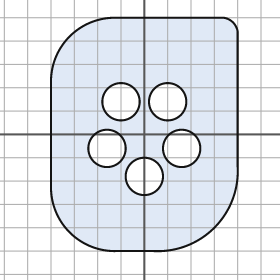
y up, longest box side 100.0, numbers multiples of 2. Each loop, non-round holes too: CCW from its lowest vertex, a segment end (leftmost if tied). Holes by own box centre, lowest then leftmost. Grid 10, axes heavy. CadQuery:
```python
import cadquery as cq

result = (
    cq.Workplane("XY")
    .moveTo(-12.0, -50.0)
    .lineTo(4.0, -50.0)
    .threePointArc((30.0, -40.0), (40.0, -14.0))
    .lineTo(40.0, 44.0)
    .threePointArc((38.0, 48.0), (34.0, 50.0))
    .lineTo(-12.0, 50.0)
    .threePointArc((-32.0, 42.0), (-40.0, 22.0))
    .lineTo(-40.0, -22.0)
    .threePointArc((-32.0, -42.0), (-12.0, -50.0))
    .close()
    .moveTo(0.0, -18.0)
    .circle(8.0)
    .moveTo(-16.0, -6.0)
    .circle(8.0)
    .moveTo(16.0, -6.0)
    .circle(8.0)
    .moveTo(-10.0, 14.0)
    .circle(8.0)
    .moveTo(10.0, 14.0)
    .circle(8.0)
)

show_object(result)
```